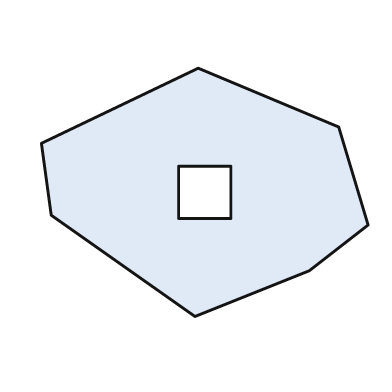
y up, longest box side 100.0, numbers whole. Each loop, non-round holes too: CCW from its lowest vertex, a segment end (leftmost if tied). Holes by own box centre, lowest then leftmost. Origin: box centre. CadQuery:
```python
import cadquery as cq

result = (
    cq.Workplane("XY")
    .moveTo(-3.0, -38.0)
    .lineTo(32.0, -24.0)
    .lineTo(50.0, -10.0)
    .lineTo(41.0, 20.0)
    .lineTo(-2.0, 38.0)
    .lineTo(-50.0, 15.0)
    .lineTo(-47.0, -7.0)
    .close()
    .moveTo(-8.0, -8.0)
    .lineTo(8.0, -8.0)
    .lineTo(8.0, 8.0)
    .lineTo(-8.0, 8.0)
    .close()
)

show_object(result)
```